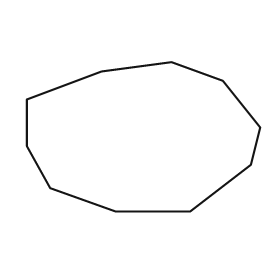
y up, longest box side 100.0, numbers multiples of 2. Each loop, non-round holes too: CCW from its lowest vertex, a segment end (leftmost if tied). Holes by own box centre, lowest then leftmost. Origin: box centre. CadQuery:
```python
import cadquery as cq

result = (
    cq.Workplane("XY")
    .moveTo(-12.0, -32.0)
    .lineTo(20.0, -32.0)
    .lineTo(46.0, -12.0)
    .lineTo(50.0, 4.0)
    .lineTo(34.0, 24.0)
    .lineTo(12.0, 32.0)
    .lineTo(-18.0, 28.0)
    .lineTo(-50.0, 16.0)
    .lineTo(-50.0, -4.0)
    .lineTo(-40.0, -22.0)
    .close()
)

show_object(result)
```